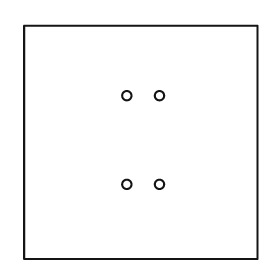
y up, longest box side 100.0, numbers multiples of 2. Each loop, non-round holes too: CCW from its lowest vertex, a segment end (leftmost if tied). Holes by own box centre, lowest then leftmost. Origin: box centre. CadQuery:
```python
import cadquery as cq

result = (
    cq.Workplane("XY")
    .moveTo(-50.0, -50.0)
    .lineTo(50.0, -50.0)
    .lineTo(50.0, 50.0)
    .lineTo(-50.0, 50.0)
    .close()
    .moveTo(-6.0, -18.0)
    .circle(2.0)
    .moveTo(8.0, -18.0)
    .circle(2.0)
    .moveTo(-6.0, 20.0)
    .circle(2.0)
    .moveTo(8.0, 20.0)
    .circle(2.0)
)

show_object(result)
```